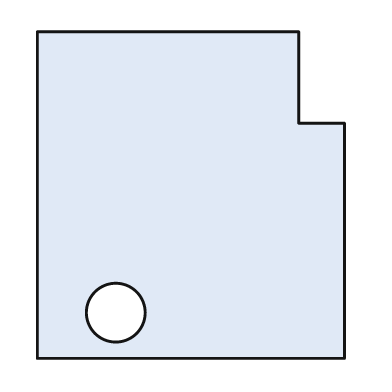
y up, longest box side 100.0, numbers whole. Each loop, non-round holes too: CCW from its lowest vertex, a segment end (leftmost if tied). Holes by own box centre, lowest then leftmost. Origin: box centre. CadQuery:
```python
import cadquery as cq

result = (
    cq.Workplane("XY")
    .moveTo(-47.0, -50.0)
    .lineTo(47.0, -50.0)
    .lineTo(47.0, 22.0)
    .lineTo(33.0, 22.0)
    .lineTo(33.0, 50.0)
    .lineTo(-47.0, 50.0)
    .close()
    .moveTo(-23.0, -36.0)
    .circle(9.0)
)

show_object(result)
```